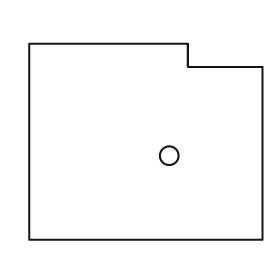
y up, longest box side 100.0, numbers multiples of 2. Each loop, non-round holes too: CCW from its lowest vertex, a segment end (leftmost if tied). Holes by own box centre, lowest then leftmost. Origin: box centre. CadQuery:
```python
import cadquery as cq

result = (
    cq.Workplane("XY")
    .moveTo(-50.0, -42.0)
    .lineTo(50.0, -42.0)
    .lineTo(50.0, 32.0)
    .lineTo(18.0, 32.0)
    .lineTo(18.0, 42.0)
    .lineTo(-50.0, 42.0)
    .close()
    .moveTo(10.0, -6.0)
    .circle(4.0)
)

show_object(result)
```